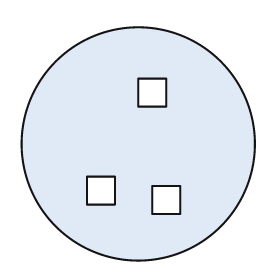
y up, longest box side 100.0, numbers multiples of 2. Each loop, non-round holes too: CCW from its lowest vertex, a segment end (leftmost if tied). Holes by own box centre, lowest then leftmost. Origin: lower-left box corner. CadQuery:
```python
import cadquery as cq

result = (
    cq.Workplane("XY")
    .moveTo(50.0, 50.0)
    .circle(50.0)
    .moveTo(56.0, 20.0)
    .lineTo(68.0, 20.0)
    .lineTo(68.0, 32.0)
    .lineTo(56.0, 32.0)
    .close()
    .moveTo(28.0, 24.0)
    .lineTo(40.0, 24.0)
    .lineTo(40.0, 36.0)
    .lineTo(28.0, 36.0)
    .close()
    .moveTo(50.0, 66.0)
    .lineTo(62.0, 66.0)
    .lineTo(62.0, 78.0)
    .lineTo(50.0, 78.0)
    .close()
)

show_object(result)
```